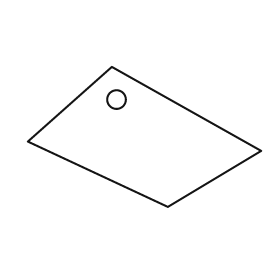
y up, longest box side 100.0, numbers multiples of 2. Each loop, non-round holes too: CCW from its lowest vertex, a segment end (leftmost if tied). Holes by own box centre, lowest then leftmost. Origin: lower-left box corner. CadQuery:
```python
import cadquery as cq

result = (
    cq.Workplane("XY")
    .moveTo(60.0, 0.0)
    .lineTo(100.0, 24.0)
    .lineTo(36.0, 60.0)
    .lineTo(0.0, 28.0)
    .close()
    .moveTo(38.0, 46.0)
    .circle(4.0)
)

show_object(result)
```